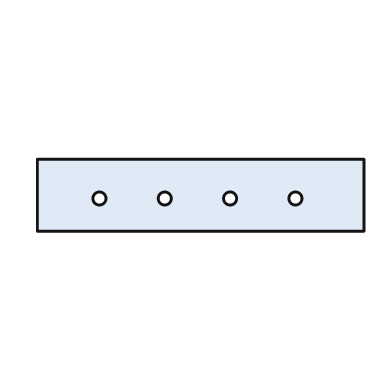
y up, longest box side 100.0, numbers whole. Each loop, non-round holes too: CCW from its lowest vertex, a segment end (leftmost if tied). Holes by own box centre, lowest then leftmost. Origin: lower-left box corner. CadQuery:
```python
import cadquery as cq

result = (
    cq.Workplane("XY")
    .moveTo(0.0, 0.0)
    .lineTo(100.0, 0.0)
    .lineTo(100.0, 22.0)
    .lineTo(0.0, 22.0)
    .close()
    .moveTo(19.0, 10.0)
    .circle(2.0)
    .moveTo(39.0, 10.0)
    .circle(2.0)
    .moveTo(59.0, 10.0)
    .circle(2.0)
    .moveTo(79.0, 10.0)
    .circle(2.0)
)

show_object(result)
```